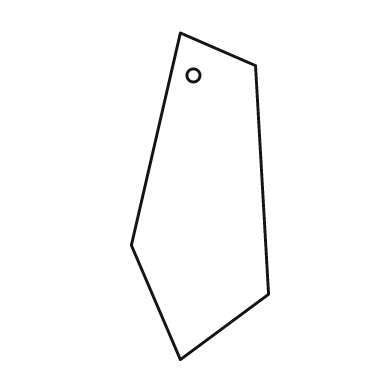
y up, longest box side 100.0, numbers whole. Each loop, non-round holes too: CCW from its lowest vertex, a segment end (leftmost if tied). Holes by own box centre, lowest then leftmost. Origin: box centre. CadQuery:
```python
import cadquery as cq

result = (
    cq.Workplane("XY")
    .moveTo(-6.0, -50.0)
    .lineTo(21.0, -30.0)
    .lineTo(17.0, 40.0)
    .lineTo(-6.0, 50.0)
    .lineTo(-21.0, -15.0)
    .close()
    .moveTo(-2.0, 37.0)
    .circle(2.0)
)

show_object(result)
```